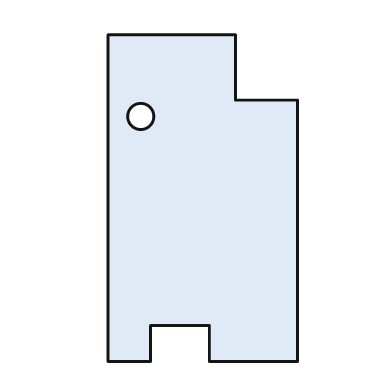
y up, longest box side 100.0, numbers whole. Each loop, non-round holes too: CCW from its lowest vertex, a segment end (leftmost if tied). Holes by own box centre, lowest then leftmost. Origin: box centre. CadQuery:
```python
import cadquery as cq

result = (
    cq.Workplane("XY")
    .moveTo(-29.0, -50.0)
    .lineTo(-16.0, -50.0)
    .lineTo(-16.0, -39.0)
    .lineTo(2.0, -39.0)
    .lineTo(2.0, -50.0)
    .lineTo(29.0, -50.0)
    .lineTo(29.0, 30.0)
    .lineTo(10.0, 30.0)
    .lineTo(10.0, 50.0)
    .lineTo(-29.0, 50.0)
    .close()
    .moveTo(-19.0, 25.0)
    .circle(4.0)
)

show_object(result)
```